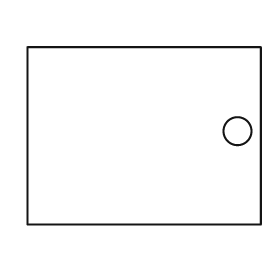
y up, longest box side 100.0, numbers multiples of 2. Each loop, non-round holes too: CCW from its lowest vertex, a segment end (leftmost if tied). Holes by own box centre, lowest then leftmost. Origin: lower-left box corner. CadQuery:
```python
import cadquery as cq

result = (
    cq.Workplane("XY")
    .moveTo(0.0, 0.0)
    .lineTo(100.0, 0.0)
    .lineTo(100.0, 76.0)
    .lineTo(0.0, 76.0)
    .close()
    .moveTo(90.0, 40.0)
    .circle(6.0)
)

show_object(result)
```